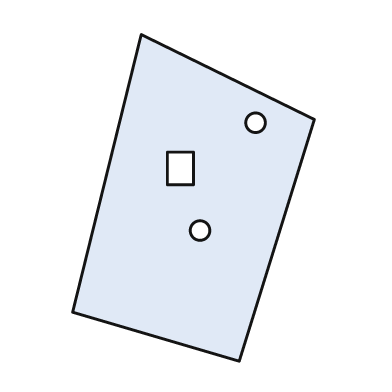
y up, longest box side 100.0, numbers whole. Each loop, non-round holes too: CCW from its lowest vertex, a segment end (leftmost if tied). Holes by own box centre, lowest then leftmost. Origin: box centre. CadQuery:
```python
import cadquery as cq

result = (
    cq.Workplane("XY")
    .moveTo(14.0, -50.0)
    .lineTo(37.0, 24.0)
    .lineTo(-16.0, 50.0)
    .lineTo(-37.0, -35.0)
    .close()
    .moveTo(2.0, -10.0)
    .circle(3.0)
    .moveTo(-8.0, 4.0)
    .lineTo(0.0, 4.0)
    .lineTo(0.0, 14.0)
    .lineTo(-8.0, 14.0)
    .close()
    .moveTo(19.0, 23.0)
    .circle(3.0)
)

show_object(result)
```